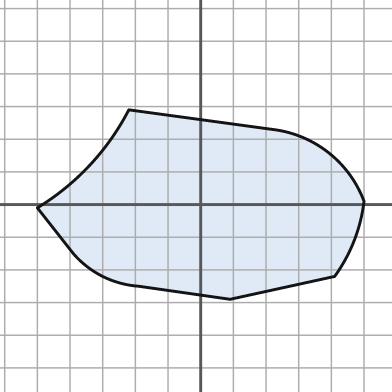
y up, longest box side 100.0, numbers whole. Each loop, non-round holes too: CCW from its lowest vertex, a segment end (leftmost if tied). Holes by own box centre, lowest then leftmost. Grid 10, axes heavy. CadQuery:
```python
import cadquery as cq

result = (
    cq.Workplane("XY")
    .moveTo(9.0, -29.0)
    .lineTo(41.0, -22.0)
    .threePointArc((47.0, -11.0), (50.0, 1.0))
    .threePointArc((39.0, 16.0), (22.0, 23.0))
    .lineTo(-22.0, 29.0)
    .threePointArc((-34.0, 12.0), (-50.0, -1.0))
    .lineTo(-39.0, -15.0)
    .threePointArc((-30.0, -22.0), (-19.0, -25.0))
    .close()
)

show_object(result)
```